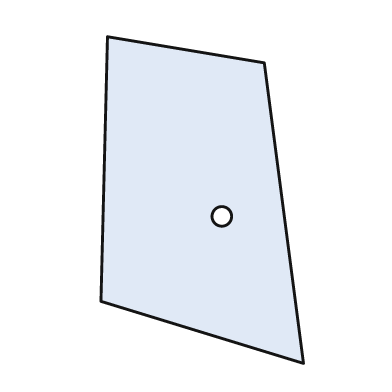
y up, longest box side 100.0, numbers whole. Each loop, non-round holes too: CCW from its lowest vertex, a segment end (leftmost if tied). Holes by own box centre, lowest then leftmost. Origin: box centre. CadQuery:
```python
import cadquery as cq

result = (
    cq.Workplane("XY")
    .moveTo(31.0, -50.0)
    .lineTo(19.0, 42.0)
    .lineTo(-29.0, 50.0)
    .lineTo(-31.0, -31.0)
    .close()
    .moveTo(6.0, -5.0)
    .circle(3.0)
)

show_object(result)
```